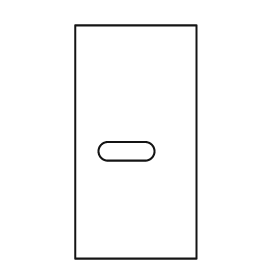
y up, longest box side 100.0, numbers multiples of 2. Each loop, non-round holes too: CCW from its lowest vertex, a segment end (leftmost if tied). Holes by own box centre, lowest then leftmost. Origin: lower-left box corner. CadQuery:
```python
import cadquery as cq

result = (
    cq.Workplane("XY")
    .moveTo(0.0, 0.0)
    .lineTo(52.0, 0.0)
    .lineTo(52.0, 100.0)
    .lineTo(0.0, 100.0)
    .close()
    .moveTo(14.0, 42.0)
    .lineTo(30.0, 42.0)
    .threePointArc((34.0, 46.0), (30.0, 50.0))
    .lineTo(14.0, 50.0)
    .threePointArc((10.0, 46.0), (14.0, 42.0))
    .close()
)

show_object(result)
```